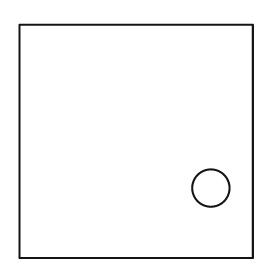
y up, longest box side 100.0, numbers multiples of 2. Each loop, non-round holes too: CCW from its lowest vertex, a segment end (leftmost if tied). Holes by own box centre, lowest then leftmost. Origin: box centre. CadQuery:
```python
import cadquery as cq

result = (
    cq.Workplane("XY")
    .moveTo(-50.0, -50.0)
    .lineTo(50.0, -50.0)
    .lineTo(50.0, 50.0)
    .lineTo(-50.0, 50.0)
    .close()
    .moveTo(32.0, -20.0)
    .circle(8.0)
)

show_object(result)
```